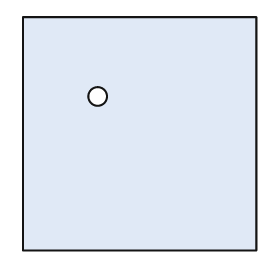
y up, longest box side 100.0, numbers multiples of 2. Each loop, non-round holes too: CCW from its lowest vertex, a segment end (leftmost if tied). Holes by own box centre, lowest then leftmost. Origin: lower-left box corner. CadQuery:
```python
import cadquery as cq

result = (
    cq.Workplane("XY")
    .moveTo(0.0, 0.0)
    .lineTo(100.0, 0.0)
    .lineTo(100.0, 100.0)
    .lineTo(0.0, 100.0)
    .close()
    .moveTo(32.0, 66.0)
    .circle(4.0)
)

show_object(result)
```